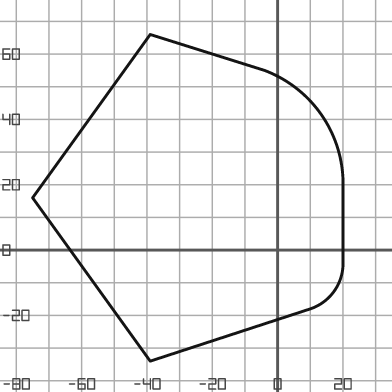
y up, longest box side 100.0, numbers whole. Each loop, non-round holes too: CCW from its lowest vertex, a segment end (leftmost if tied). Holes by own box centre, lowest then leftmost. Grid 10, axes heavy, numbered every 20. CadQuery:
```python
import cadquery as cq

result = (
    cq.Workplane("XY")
    .moveTo(-39.0, -34.0)
    .lineTo(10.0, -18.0)
    .threePointArc((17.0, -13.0), (20.0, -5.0))
    .lineTo(20.0, 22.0)
    .threePointArc((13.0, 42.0), (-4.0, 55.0))
    .lineTo(-39.0, 66.0)
    .lineTo(-75.0, 16.0)
    .close()
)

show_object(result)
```